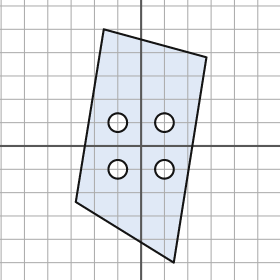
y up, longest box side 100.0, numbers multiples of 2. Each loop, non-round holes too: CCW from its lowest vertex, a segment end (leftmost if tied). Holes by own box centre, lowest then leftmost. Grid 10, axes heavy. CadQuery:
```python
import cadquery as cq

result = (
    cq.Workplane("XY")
    .moveTo(14.0, -50.0)
    .lineTo(28.0, 38.0)
    .lineTo(-16.0, 50.0)
    .lineTo(-28.0, -24.0)
    .close()
    .moveTo(-10.0, -10.0)
    .circle(4.0)
    .moveTo(10.0, -10.0)
    .circle(4.0)
    .moveTo(-10.0, 10.0)
    .circle(4.0)
    .moveTo(10.0, 10.0)
    .circle(4.0)
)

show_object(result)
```